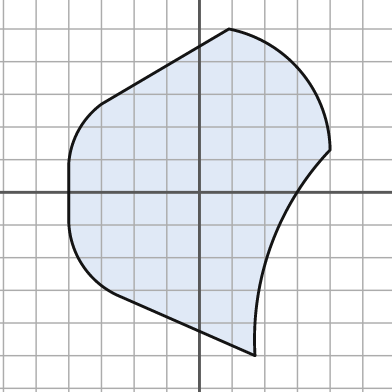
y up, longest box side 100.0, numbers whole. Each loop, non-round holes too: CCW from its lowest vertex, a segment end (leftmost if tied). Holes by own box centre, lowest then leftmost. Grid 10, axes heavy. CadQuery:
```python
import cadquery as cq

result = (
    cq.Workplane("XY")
    .moveTo(17.0, -50.0)
    .threePointArc((22.0, -16.0), (40.0, 13.0))
    .threePointArc((31.0, 37.0), (9.0, 50.0))
    .lineTo(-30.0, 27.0)
    .threePointArc((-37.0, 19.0), (-40.0, 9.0))
    .lineTo(-40.0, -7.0)
    .threePointArc((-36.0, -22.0), (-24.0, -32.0))
    .close()
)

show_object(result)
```